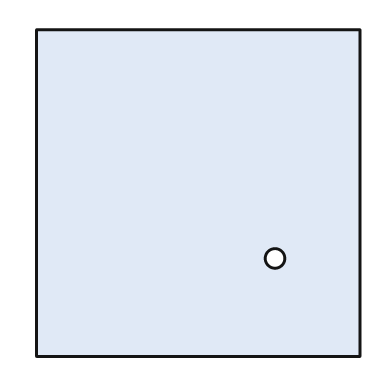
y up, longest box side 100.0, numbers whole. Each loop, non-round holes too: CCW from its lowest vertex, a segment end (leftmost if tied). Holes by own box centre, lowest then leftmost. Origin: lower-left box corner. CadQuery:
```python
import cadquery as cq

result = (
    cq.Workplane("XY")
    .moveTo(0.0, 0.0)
    .lineTo(99.0, 0.0)
    .lineTo(99.0, 100.0)
    .lineTo(0.0, 100.0)
    .close()
    .moveTo(73.0, 30.0)
    .circle(3.0)
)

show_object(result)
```